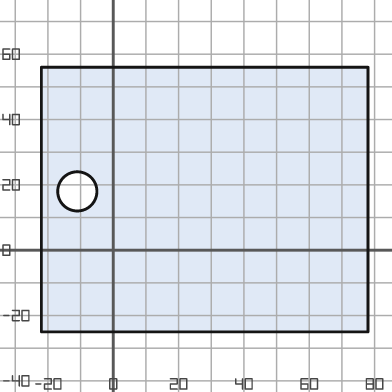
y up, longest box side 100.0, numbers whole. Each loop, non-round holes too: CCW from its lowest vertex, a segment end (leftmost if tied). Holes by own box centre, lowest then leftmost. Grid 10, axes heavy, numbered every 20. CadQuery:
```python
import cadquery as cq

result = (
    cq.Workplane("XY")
    .moveTo(-22.0, -25.0)
    .lineTo(78.0, -25.0)
    .lineTo(78.0, 56.0)
    .lineTo(-22.0, 56.0)
    .close()
    .moveTo(-11.0, 18.0)
    .circle(6.0)
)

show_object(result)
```